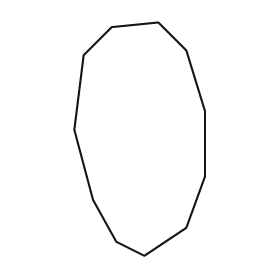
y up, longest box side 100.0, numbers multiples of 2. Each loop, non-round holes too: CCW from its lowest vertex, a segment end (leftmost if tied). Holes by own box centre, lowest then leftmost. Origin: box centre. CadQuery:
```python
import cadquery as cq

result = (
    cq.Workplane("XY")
    .moveTo(2.0, -50.0)
    .lineTo(20.0, -38.0)
    .lineTo(28.0, -16.0)
    .lineTo(28.0, 12.0)
    .lineTo(20.0, 38.0)
    .lineTo(8.0, 50.0)
    .lineTo(-12.0, 48.0)
    .lineTo(-24.0, 36.0)
    .lineTo(-28.0, 4.0)
    .lineTo(-20.0, -26.0)
    .lineTo(-10.0, -44.0)
    .close()
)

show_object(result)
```